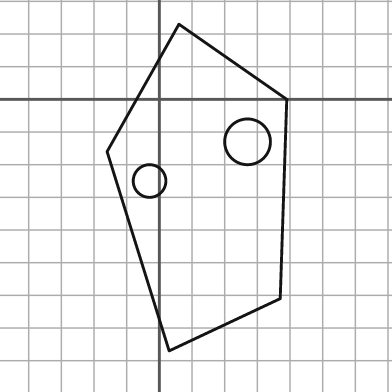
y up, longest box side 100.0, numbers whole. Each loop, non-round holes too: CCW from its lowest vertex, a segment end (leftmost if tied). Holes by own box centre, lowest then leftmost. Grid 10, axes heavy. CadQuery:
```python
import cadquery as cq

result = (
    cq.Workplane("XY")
    .moveTo(3.0, -77.0)
    .lineTo(37.0, -61.0)
    .lineTo(39.0, 0.0)
    .lineTo(6.0, 23.0)
    .lineTo(-16.0, -16.0)
    .close()
    .moveTo(-3.0, -25.0)
    .circle(5.0)
    .moveTo(27.0, -13.0)
    .circle(7.0)
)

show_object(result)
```